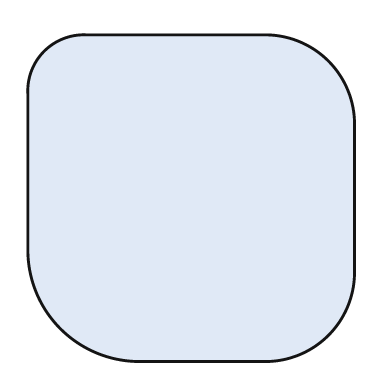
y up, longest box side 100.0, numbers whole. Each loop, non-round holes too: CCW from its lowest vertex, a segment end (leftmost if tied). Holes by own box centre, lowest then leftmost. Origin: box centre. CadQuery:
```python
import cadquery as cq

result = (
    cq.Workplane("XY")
    .moveTo(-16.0, -50.0)
    .lineTo(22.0, -50.0)
    .threePointArc((42.0, -42.0), (50.0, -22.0))
    .lineTo(50.0, 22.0)
    .threePointArc((42.0, 42.0), (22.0, 50.0))
    .lineTo(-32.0, 50.0)
    .threePointArc((-45.0, 45.0), (-50.0, 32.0))
    .lineTo(-50.0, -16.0)
    .threePointArc((-40.0, -40.0), (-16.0, -50.0))
    .close()
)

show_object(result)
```